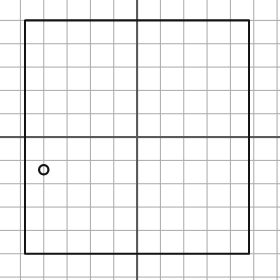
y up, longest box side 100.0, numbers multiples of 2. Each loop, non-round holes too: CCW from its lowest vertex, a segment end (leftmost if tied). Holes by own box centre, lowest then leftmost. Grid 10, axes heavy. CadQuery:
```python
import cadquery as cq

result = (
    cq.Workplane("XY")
    .moveTo(-48.0, -50.0)
    .lineTo(48.0, -50.0)
    .lineTo(48.0, 50.0)
    .lineTo(-48.0, 50.0)
    .close()
    .moveTo(-40.0, -14.0)
    .circle(2.0)
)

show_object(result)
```